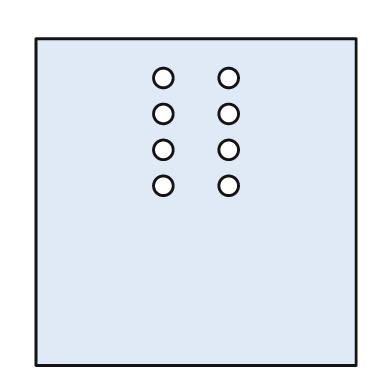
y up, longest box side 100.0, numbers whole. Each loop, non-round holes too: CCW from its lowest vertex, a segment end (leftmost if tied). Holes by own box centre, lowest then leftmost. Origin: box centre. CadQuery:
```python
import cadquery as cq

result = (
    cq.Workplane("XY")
    .moveTo(-49.0, -50.0)
    .lineTo(49.0, -50.0)
    .lineTo(49.0, 50.0)
    .lineTo(-49.0, 50.0)
    .close()
    .moveTo(-10.0, 5.0)
    .circle(3.0)
    .moveTo(10.0, 5.0)
    .circle(3.0)
    .moveTo(-10.0, 16.0)
    .circle(3.0)
    .moveTo(10.0, 16.0)
    .circle(3.0)
    .moveTo(-10.0, 27.0)
    .circle(3.0)
    .moveTo(10.0, 27.0)
    .circle(3.0)
    .moveTo(-10.0, 38.0)
    .circle(3.0)
    .moveTo(10.0, 38.0)
    .circle(3.0)
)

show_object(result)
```